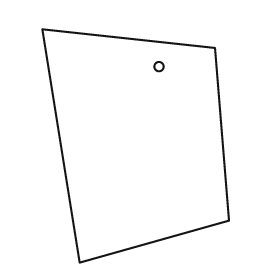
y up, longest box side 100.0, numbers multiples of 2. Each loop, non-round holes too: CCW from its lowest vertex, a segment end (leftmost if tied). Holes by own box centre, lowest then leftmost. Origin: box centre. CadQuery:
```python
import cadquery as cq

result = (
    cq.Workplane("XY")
    .moveTo(-24.0, -50.0)
    .lineTo(40.0, -32.0)
    .lineTo(34.0, 42.0)
    .lineTo(-40.0, 50.0)
    .close()
    .moveTo(10.0, 34.0)
    .circle(2.0)
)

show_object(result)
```